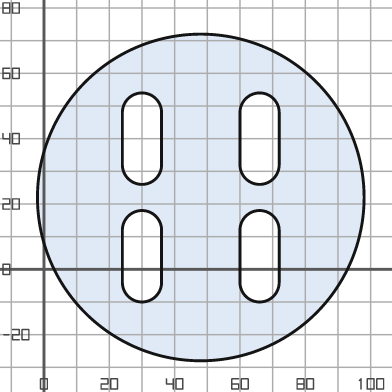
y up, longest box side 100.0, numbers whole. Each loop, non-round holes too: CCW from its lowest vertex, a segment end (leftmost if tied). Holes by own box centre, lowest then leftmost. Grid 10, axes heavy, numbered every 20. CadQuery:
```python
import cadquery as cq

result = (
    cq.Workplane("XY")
    .moveTo(48.0, 22.0)
    .circle(50.0)
    .moveTo(24.0, -4.0)
    .threePointArc((30.0, -10.0), (36.0, -4.0))
    .lineTo(36.0, 12.0)
    .threePointArc((30.0, 18.0), (24.0, 12.0))
    .close()
    .moveTo(60.0, -4.0)
    .threePointArc((66.0, -10.0), (72.0, -4.0))
    .lineTo(72.0, 12.0)
    .threePointArc((66.0, 18.0), (60.0, 12.0))
    .close()
    .moveTo(24.0, 32.0)
    .threePointArc((30.0, 26.0), (36.0, 32.0))
    .lineTo(36.0, 48.0)
    .threePointArc((30.0, 54.0), (24.0, 48.0))
    .close()
    .moveTo(60.0, 32.0)
    .threePointArc((66.0, 26.0), (72.0, 32.0))
    .lineTo(72.0, 48.0)
    .threePointArc((66.0, 54.0), (60.0, 48.0))
    .close()
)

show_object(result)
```